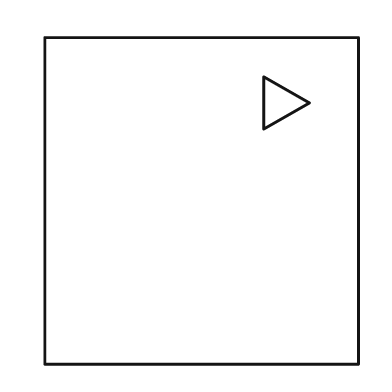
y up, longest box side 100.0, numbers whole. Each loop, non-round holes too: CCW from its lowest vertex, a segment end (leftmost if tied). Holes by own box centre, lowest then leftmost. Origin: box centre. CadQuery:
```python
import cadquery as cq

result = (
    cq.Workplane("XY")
    .moveTo(-48.0, -50.0)
    .lineTo(48.0, -50.0)
    .lineTo(48.0, 50.0)
    .lineTo(-48.0, 50.0)
    .close()
    .moveTo(19.0, 22.0)
    .lineTo(33.0, 30.0)
    .lineTo(19.0, 38.0)
    .close()
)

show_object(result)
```